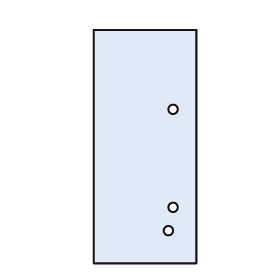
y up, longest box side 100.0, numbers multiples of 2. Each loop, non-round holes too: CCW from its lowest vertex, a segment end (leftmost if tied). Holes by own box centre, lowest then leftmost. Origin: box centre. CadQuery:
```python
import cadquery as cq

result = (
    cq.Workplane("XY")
    .moveTo(-22.0, -50.0)
    .lineTo(22.0, -50.0)
    .lineTo(22.0, 50.0)
    .lineTo(-22.0, 50.0)
    .close()
    .moveTo(10.0, -36.0)
    .circle(2.0)
    .moveTo(12.0, -26.0)
    .circle(2.0)
    .moveTo(12.0, 16.0)
    .circle(2.0)
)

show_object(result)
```